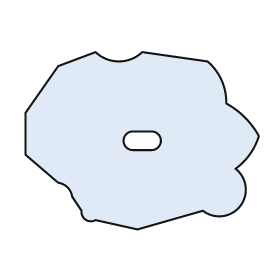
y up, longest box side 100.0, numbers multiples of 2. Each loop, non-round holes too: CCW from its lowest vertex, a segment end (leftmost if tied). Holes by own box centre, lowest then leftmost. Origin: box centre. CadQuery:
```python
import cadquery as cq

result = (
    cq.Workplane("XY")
    .moveTo(-2.0, -38.0)
    .lineTo(26.0, -30.0)
    .threePointArc((42.0, -28.0), (40.0, -12.0))
    .threePointArc((46.0, -6.0), (50.0, 2.0))
    .threePointArc((44.0, 10.0), (36.0, 16.0))
    .threePointArc((34.0, 26.0), (28.0, 34.0))
    .lineTo(0.0, 38.0)
    .threePointArc((-10.0, 34.0), (-20.0, 38.0))
    .lineTo(-36.0, 32.0)
    .lineTo(-50.0, 12.0)
    .lineTo(-50.0, -6.0)
    .lineTo(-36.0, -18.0)
    .threePointArc((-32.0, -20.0), (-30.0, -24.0))
    .lineTo(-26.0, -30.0)
    .threePointArc((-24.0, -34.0), (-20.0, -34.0))
    .close()
    .moveTo(-4.0, -4.0)
    .lineTo(4.0, -4.0)
    .threePointArc((8.0, 0.0), (4.0, 4.0))
    .lineTo(-4.0, 4.0)
    .threePointArc((-8.0, 0.0), (-4.0, -4.0))
    .close()
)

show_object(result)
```